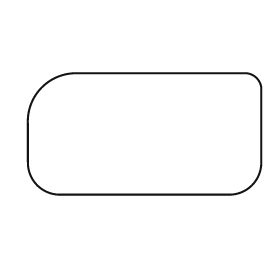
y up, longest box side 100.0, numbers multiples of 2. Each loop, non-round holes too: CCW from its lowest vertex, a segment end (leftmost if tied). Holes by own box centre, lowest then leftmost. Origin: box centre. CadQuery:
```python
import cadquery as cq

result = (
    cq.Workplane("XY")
    .moveTo(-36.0, -26.0)
    .lineTo(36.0, -26.0)
    .threePointArc((46.0, -22.0), (50.0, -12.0))
    .lineTo(50.0, 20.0)
    .threePointArc((48.0, 24.0), (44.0, 26.0))
    .lineTo(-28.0, 26.0)
    .threePointArc((-44.0, 20.0), (-50.0, 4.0))
    .lineTo(-50.0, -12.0)
    .threePointArc((-46.0, -22.0), (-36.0, -26.0))
    .close()
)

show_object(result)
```